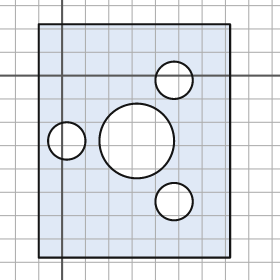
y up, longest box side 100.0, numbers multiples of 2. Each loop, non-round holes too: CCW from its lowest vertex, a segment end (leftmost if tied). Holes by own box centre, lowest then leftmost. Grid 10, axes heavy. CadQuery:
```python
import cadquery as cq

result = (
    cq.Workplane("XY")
    .moveTo(-10.0, -78.0)
    .lineTo(72.0, -78.0)
    .lineTo(72.0, 22.0)
    .lineTo(-10.0, 22.0)
    .close()
    .moveTo(48.0, -54.0)
    .circle(8.0)
    .moveTo(2.0, -28.0)
    .circle(8.0)
    .moveTo(32.0, -28.0)
    .circle(16.0)
    .moveTo(48.0, -2.0)
    .circle(8.0)
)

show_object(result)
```